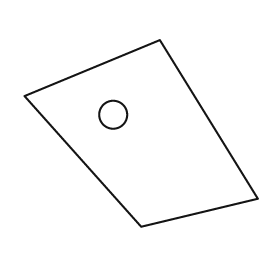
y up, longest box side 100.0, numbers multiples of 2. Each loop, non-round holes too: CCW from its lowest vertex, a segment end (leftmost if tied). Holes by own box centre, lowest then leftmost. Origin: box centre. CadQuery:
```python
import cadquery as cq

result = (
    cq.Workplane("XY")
    .moveTo(0.0, -40.0)
    .lineTo(50.0, -28.0)
    .lineTo(8.0, 40.0)
    .lineTo(-50.0, 16.0)
    .close()
    .moveTo(-12.0, 8.0)
    .circle(6.0)
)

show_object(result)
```